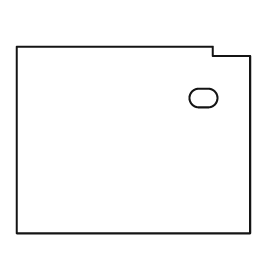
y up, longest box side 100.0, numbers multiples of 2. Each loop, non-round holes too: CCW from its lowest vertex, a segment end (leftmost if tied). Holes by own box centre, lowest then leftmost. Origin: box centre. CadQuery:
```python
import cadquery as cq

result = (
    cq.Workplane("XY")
    .moveTo(-50.0, -40.0)
    .lineTo(50.0, -40.0)
    .lineTo(50.0, 36.0)
    .lineTo(34.0, 36.0)
    .lineTo(34.0, 40.0)
    .lineTo(-50.0, 40.0)
    .close()
    .moveTo(28.0, 14.0)
    .lineTo(32.0, 14.0)
    .threePointArc((36.0, 18.0), (32.0, 22.0))
    .lineTo(28.0, 22.0)
    .threePointArc((24.0, 18.0), (28.0, 14.0))
    .close()
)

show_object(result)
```